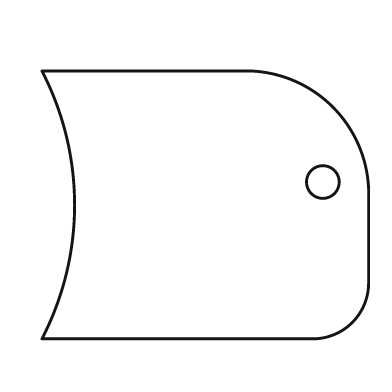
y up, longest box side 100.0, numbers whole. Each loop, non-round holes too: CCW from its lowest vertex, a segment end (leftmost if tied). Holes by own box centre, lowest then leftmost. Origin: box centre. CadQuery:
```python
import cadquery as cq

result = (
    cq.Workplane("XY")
    .moveTo(-50.0, -41.0)
    .lineTo(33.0, -41.0)
    .threePointArc((45.0, -36.0), (50.0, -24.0))
    .lineTo(50.0, 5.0)
    .threePointArc((39.0, 30.0), (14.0, 41.0))
    .lineTo(-50.0, 41.0)
    .threePointArc((-40.0, 0.0), (-50.0, -41.0))
    .close()
    .moveTo(36.0, 7.0)
    .circle(5.0)
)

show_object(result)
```